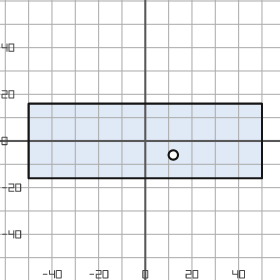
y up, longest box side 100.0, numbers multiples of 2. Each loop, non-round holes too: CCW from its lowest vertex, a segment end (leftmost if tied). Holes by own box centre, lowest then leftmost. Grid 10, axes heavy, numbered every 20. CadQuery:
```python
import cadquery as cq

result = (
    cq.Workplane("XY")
    .moveTo(-50.0, -16.0)
    .lineTo(50.0, -16.0)
    .lineTo(50.0, 16.0)
    .lineTo(-50.0, 16.0)
    .close()
    .moveTo(12.0, -6.0)
    .circle(2.0)
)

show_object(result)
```